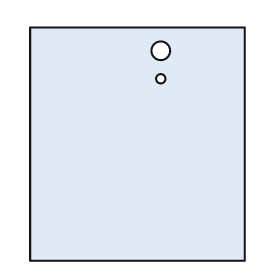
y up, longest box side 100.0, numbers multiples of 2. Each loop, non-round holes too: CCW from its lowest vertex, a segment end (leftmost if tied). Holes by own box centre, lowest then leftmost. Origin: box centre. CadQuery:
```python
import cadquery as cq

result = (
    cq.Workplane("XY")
    .moveTo(-46.0, -50.0)
    .lineTo(46.0, -50.0)
    .lineTo(46.0, 50.0)
    .lineTo(-46.0, 50.0)
    .close()
    .moveTo(10.0, 28.0)
    .circle(2.0)
    .moveTo(10.0, 40.0)
    .circle(4.0)
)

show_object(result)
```